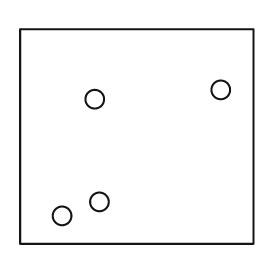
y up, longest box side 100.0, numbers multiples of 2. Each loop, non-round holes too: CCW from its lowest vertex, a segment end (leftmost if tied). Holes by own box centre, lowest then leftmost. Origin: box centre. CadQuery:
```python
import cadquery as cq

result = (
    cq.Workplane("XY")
    .moveTo(-50.0, -46.0)
    .lineTo(50.0, -46.0)
    .lineTo(50.0, 46.0)
    .lineTo(-50.0, 46.0)
    .close()
    .moveTo(-32.0, -34.0)
    .circle(4.0)
    .moveTo(-16.0, -28.0)
    .circle(4.0)
    .moveTo(-18.0, 16.0)
    .circle(4.0)
    .moveTo(36.0, 20.0)
    .circle(4.0)
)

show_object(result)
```